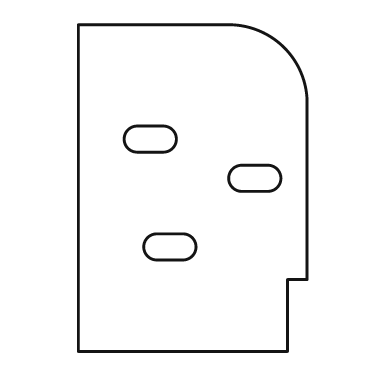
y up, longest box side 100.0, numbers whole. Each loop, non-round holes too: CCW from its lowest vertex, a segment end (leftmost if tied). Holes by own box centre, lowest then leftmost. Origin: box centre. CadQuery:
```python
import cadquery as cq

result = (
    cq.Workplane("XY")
    .moveTo(-35.0, -50.0)
    .lineTo(29.0, -50.0)
    .lineTo(29.0, -28.0)
    .lineTo(35.0, -28.0)
    .lineTo(35.0, 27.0)
    .threePointArc((28.0, 43.0), (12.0, 50.0))
    .lineTo(-35.0, 50.0)
    .close()
    .moveTo(-11.0, -22.0)
    .lineTo(-3.0, -22.0)
    .threePointArc((1.0, -18.0), (-3.0, -14.0))
    .lineTo(-11.0, -14.0)
    .threePointArc((-15.0, -18.0), (-11.0, -22.0))
    .close()
    .moveTo(15.0, -1.0)
    .lineTo(23.0, -1.0)
    .threePointArc((27.0, 3.0), (23.0, 7.0))
    .lineTo(15.0, 7.0)
    .threePointArc((11.0, 3.0), (15.0, -1.0))
    .close()
    .moveTo(-17.0, 11.0)
    .lineTo(-9.0, 11.0)
    .threePointArc((-5.0, 15.0), (-9.0, 19.0))
    .lineTo(-17.0, 19.0)
    .threePointArc((-21.0, 15.0), (-17.0, 11.0))
    .close()
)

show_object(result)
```